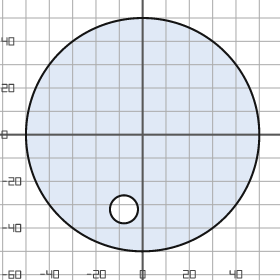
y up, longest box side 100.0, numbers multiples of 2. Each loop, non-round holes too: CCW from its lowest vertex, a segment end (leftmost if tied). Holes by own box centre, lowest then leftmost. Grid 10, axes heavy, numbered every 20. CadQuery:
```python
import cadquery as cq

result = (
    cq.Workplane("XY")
    .moveTo(0.0, 0.0)
    .circle(50.0)
    .moveTo(-8.0, -32.0)
    .circle(6.0)
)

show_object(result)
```